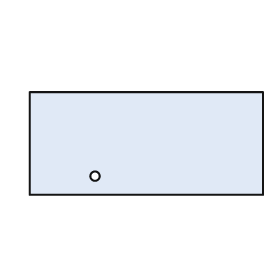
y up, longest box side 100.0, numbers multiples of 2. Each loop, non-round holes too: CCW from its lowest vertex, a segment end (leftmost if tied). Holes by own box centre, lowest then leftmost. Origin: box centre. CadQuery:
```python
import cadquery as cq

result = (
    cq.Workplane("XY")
    .moveTo(-50.0, -22.0)
    .lineTo(50.0, -22.0)
    .lineTo(50.0, 22.0)
    .lineTo(-50.0, 22.0)
    .close()
    .moveTo(-22.0, -14.0)
    .circle(2.0)
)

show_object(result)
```